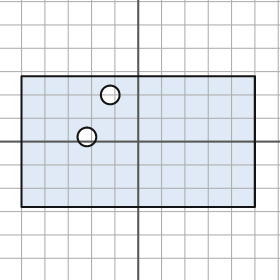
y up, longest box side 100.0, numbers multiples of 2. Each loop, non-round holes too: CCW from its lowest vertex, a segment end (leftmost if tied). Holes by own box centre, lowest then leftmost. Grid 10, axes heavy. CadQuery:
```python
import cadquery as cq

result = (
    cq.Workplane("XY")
    .moveTo(-50.0, -28.0)
    .lineTo(50.0, -28.0)
    .lineTo(50.0, 28.0)
    .lineTo(-50.0, 28.0)
    .close()
    .moveTo(-22.0, 2.0)
    .circle(4.0)
    .moveTo(-12.0, 20.0)
    .circle(4.0)
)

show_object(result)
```